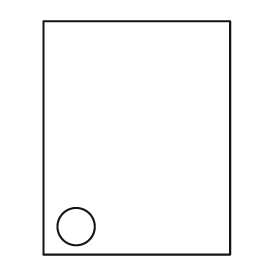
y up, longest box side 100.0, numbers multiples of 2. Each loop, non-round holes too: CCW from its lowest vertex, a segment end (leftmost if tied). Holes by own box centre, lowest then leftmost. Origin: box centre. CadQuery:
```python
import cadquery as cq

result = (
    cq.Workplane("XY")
    .moveTo(-40.0, -50.0)
    .lineTo(40.0, -50.0)
    .lineTo(40.0, 50.0)
    .lineTo(-40.0, 50.0)
    .close()
    .moveTo(-26.0, -38.0)
    .circle(8.0)
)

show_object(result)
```